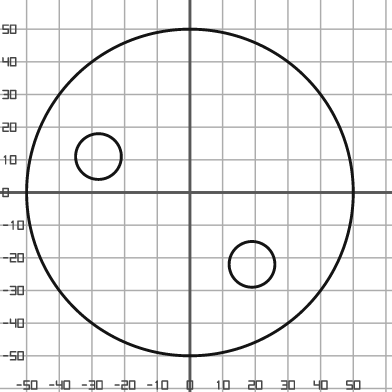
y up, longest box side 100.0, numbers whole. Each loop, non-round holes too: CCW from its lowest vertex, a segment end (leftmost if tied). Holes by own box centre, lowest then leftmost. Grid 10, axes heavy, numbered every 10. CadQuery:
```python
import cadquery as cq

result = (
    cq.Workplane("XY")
    .moveTo(0.0, 0.0)
    .circle(50.0)
    .moveTo(19.0, -22.0)
    .circle(7.0)
    .moveTo(-28.0, 11.0)
    .circle(7.0)
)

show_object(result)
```